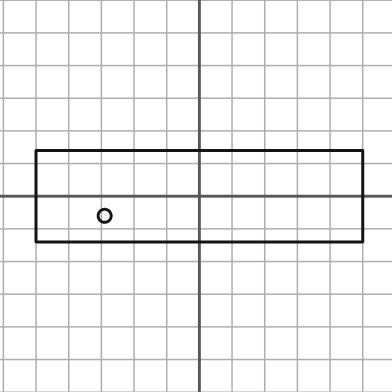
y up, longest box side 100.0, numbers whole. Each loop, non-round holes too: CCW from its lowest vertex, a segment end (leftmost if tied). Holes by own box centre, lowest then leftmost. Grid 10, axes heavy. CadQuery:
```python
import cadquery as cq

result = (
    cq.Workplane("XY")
    .moveTo(-50.0, -14.0)
    .lineTo(50.0, -14.0)
    .lineTo(50.0, 14.0)
    .lineTo(-50.0, 14.0)
    .close()
    .moveTo(-29.0, -6.0)
    .circle(2.0)
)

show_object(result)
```